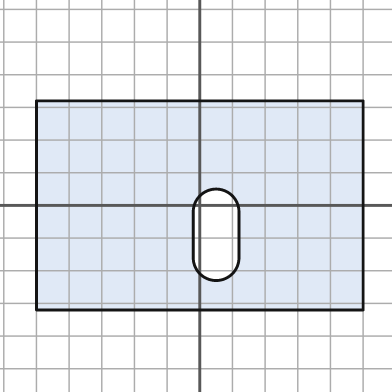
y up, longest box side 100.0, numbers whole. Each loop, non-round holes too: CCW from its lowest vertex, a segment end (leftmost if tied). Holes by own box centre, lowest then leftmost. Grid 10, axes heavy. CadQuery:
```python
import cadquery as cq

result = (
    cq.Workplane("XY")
    .moveTo(-50.0, -32.0)
    .lineTo(50.0, -32.0)
    .lineTo(50.0, 32.0)
    .lineTo(-50.0, 32.0)
    .close()
    .moveTo(-2.0, -16.0)
    .threePointArc((5.0, -23.0), (12.0, -16.0))
    .lineTo(12.0, -2.0)
    .threePointArc((5.0, 5.0), (-2.0, -2.0))
    .close()
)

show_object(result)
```